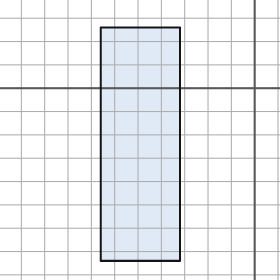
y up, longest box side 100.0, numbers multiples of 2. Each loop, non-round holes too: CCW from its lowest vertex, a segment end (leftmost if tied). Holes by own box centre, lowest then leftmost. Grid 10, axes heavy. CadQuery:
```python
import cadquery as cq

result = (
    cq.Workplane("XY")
    .moveTo(-66.0, -74.0)
    .lineTo(-32.0, -74.0)
    .lineTo(-32.0, 26.0)
    .lineTo(-66.0, 26.0)
    .close()
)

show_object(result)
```